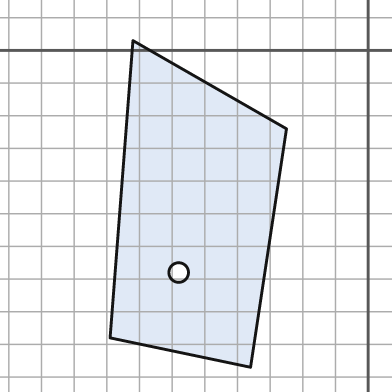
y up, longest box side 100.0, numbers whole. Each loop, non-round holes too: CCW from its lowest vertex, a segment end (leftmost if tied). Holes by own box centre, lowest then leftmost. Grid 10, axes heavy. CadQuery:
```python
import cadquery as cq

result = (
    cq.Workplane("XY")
    .moveTo(-36.0, -97.0)
    .lineTo(-25.0, -24.0)
    .lineTo(-72.0, 3.0)
    .lineTo(-79.0, -88.0)
    .close()
    .moveTo(-58.0, -68.0)
    .circle(3.0)
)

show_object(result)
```